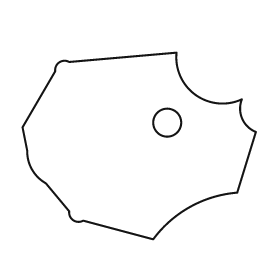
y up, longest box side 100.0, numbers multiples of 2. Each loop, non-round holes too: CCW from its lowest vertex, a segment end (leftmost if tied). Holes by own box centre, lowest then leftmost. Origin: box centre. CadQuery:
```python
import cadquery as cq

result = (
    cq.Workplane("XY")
    .moveTo(6.0, -40.0)
    .threePointArc((22.0, -26.0), (42.0, -20.0))
    .lineTo(50.0, 6.0)
    .threePointArc((44.0, 12.0), (44.0, 20.0))
    .threePointArc((24.0, 22.0), (16.0, 40.0))
    .lineTo(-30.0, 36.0)
    .threePointArc((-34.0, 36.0), (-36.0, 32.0))
    .lineTo(-50.0, 8.0)
    .lineTo(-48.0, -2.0)
    .threePointArc((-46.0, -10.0), (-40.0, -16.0))
    .lineTo(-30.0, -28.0)
    .threePointArc((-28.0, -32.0), (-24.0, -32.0))
    .close()
    .moveTo(12.0, 10.0)
    .circle(6.0)
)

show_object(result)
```